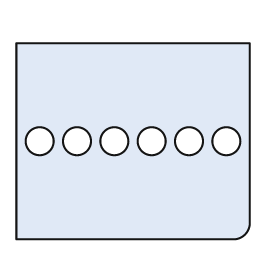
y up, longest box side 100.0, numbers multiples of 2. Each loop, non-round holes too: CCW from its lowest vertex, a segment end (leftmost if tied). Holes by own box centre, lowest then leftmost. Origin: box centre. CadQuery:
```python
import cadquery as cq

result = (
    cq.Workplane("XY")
    .moveTo(-50.0, -42.0)
    .lineTo(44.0, -42.0)
    .threePointArc((48.0, -40.0), (50.0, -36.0))
    .lineTo(50.0, 42.0)
    .lineTo(-50.0, 42.0)
    .close()
    .moveTo(-40.0, 0.0)
    .circle(6.0)
    .moveTo(-24.0, 0.0)
    .circle(6.0)
    .moveTo(-8.0, 0.0)
    .circle(6.0)
    .moveTo(8.0, 0.0)
    .circle(6.0)
    .moveTo(24.0, 0.0)
    .circle(6.0)
    .moveTo(40.0, 0.0)
    .circle(6.0)
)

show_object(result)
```